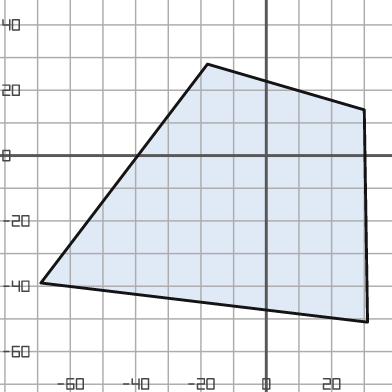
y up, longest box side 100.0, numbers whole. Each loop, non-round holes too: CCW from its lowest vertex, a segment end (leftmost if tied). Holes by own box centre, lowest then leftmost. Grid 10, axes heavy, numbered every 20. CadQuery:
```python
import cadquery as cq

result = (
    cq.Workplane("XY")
    .moveTo(31.0, -51.0)
    .lineTo(30.0, 14.0)
    .lineTo(-18.0, 28.0)
    .lineTo(-69.0, -39.0)
    .close()
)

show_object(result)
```